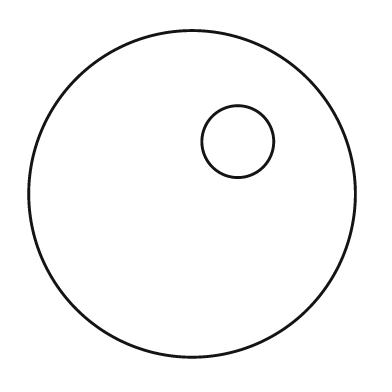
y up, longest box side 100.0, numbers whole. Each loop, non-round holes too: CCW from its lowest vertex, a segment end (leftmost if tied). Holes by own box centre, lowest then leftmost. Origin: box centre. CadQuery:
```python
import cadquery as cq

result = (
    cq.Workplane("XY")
    .moveTo(0.0, 0.0)
    .circle(50.0)
    .moveTo(14.0, 16.0)
    .circle(11.0)
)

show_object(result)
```